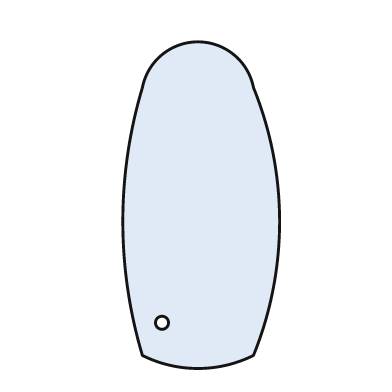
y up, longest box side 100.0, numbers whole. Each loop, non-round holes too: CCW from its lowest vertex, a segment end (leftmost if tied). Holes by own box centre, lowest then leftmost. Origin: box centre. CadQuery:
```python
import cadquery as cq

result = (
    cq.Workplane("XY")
    .moveTo(-18.0, -46.0)
    .threePointArc((-1.0, -50.0), (16.0, -46.0))
    .threePointArc((24.0, -5.0), (16.0, 36.0))
    .threePointArc((-1.0, 50.0), (-18.0, 36.0))
    .threePointArc((-24.0, -5.0), (-18.0, -46.0))
    .close()
    .moveTo(-12.0, -36.0)
    .circle(2.0)
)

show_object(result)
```